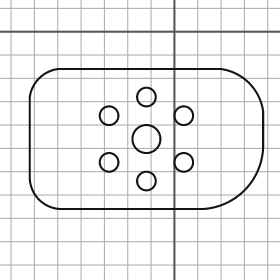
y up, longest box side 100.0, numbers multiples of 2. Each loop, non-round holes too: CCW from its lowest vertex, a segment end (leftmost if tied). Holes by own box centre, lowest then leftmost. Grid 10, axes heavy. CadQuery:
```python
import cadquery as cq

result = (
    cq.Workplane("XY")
    .moveTo(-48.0, -76.0)
    .lineTo(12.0, -76.0)
    .threePointArc((30.0, -68.0), (38.0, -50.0))
    .lineTo(38.0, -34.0)
    .threePointArc((32.0, -22.0), (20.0, -16.0))
    .lineTo(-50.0, -16.0)
    .threePointArc((-58.0, -20.0), (-62.0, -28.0))
    .lineTo(-62.0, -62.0)
    .threePointArc((-58.0, -72.0), (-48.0, -76.0))
    .close()
    .moveTo(-12.0, -64.0)
    .circle(4.0)
    .moveTo(-28.0, -56.0)
    .circle(4.0)
    .moveTo(4.0, -56.0)
    .circle(4.0)
    .moveTo(-12.0, -46.0)
    .circle(6.0)
    .moveTo(-28.0, -36.0)
    .circle(4.0)
    .moveTo(4.0, -36.0)
    .circle(4.0)
    .moveTo(-12.0, -28.0)
    .circle(4.0)
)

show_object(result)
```